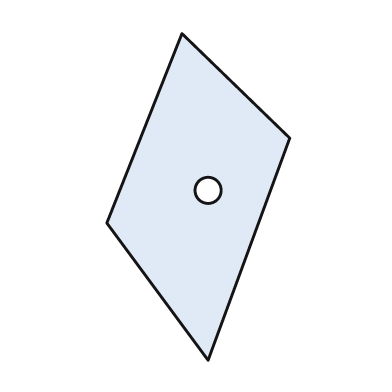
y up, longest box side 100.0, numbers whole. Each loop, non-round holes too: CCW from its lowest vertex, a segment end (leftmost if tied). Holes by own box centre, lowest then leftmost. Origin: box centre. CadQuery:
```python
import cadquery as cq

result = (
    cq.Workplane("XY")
    .moveTo(3.0, -50.0)
    .lineTo(28.0, 18.0)
    .lineTo(-5.0, 50.0)
    .lineTo(-28.0, -8.0)
    .close()
    .moveTo(3.0, 2.0)
    .circle(4.0)
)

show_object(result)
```